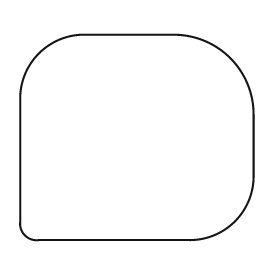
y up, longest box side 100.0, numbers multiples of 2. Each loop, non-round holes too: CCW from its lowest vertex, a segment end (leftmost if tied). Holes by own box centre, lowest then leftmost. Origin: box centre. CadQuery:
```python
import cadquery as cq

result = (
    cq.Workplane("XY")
    .moveTo(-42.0, -44.0)
    .lineTo(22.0, -44.0)
    .threePointArc((42.0, -36.0), (50.0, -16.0))
    .lineTo(50.0, 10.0)
    .threePointArc((40.0, 34.0), (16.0, 44.0))
    .lineTo(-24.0, 44.0)
    .threePointArc((-42.0, 36.0), (-50.0, 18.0))
    .lineTo(-50.0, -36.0)
    .threePointArc((-48.0, -42.0), (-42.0, -44.0))
    .close()
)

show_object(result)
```